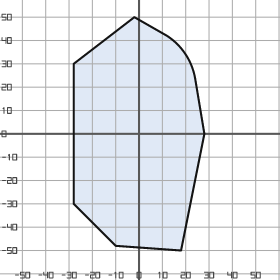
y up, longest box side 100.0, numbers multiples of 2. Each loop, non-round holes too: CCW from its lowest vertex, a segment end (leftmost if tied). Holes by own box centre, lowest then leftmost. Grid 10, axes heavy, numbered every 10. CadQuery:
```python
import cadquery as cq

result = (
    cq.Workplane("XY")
    .moveTo(18.0, -50.0)
    .lineTo(28.0, 0.0)
    .lineTo(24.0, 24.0)
    .threePointArc((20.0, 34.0), (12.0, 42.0))
    .lineTo(-2.0, 50.0)
    .lineTo(-28.0, 30.0)
    .lineTo(-28.0, -30.0)
    .lineTo(-10.0, -48.0)
    .close()
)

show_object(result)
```